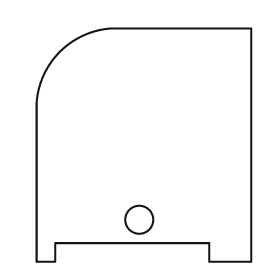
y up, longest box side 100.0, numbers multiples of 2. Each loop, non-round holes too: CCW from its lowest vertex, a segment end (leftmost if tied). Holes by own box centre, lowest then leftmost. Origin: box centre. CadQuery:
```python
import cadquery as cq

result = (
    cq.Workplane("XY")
    .moveTo(-46.0, -50.0)
    .lineTo(-38.0, -50.0)
    .lineTo(-38.0, -42.0)
    .lineTo(28.0, -42.0)
    .lineTo(28.0, -50.0)
    .lineTo(46.0, -50.0)
    .lineTo(46.0, 50.0)
    .lineTo(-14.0, 50.0)
    .threePointArc((-36.0, 40.0), (-46.0, 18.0))
    .close()
    .moveTo(-2.0, -32.0)
    .circle(6.0)
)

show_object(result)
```